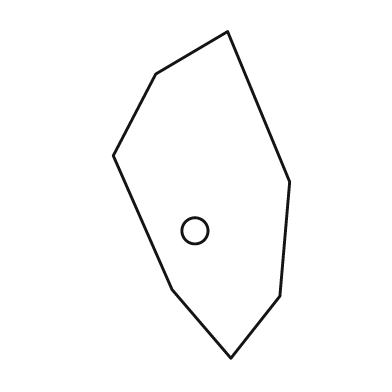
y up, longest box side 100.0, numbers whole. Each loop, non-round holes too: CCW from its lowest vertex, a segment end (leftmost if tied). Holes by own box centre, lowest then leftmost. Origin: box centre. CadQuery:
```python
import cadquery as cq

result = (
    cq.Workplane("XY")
    .moveTo(9.0, -50.0)
    .lineTo(24.0, -31.0)
    .lineTo(27.0, 4.0)
    .lineTo(8.0, 50.0)
    .lineTo(-14.0, 37.0)
    .lineTo(-27.0, 12.0)
    .lineTo(-9.0, -29.0)
    .close()
    .moveTo(-2.0, -11.0)
    .circle(4.0)
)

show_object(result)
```